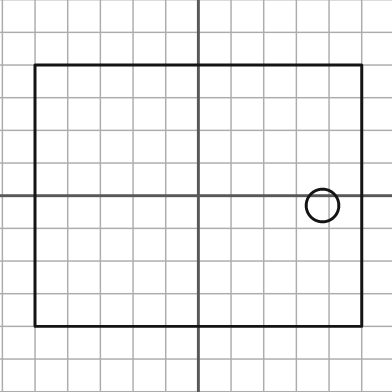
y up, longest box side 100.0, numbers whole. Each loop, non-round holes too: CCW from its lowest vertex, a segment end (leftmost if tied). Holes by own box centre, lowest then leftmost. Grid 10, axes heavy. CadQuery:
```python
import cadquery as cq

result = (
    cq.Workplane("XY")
    .moveTo(-50.0, -40.0)
    .lineTo(50.0, -40.0)
    .lineTo(50.0, 40.0)
    .lineTo(-50.0, 40.0)
    .close()
    .moveTo(38.0, -3.0)
    .circle(5.0)
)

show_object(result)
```